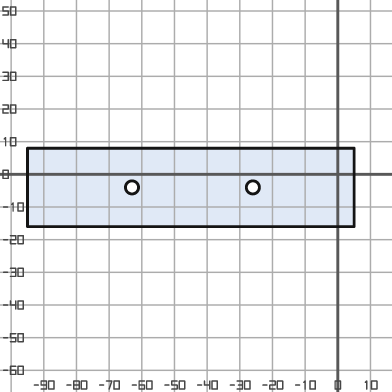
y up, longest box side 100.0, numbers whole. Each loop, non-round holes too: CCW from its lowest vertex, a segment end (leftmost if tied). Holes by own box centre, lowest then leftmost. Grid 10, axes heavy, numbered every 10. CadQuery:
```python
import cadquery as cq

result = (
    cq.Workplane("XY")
    .moveTo(-95.0, -16.0)
    .lineTo(5.0, -16.0)
    .lineTo(5.0, 8.0)
    .lineTo(-95.0, 8.0)
    .close()
    .moveTo(-63.0, -4.0)
    .circle(2.0)
    .moveTo(-26.0, -4.0)
    .circle(2.0)
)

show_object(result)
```